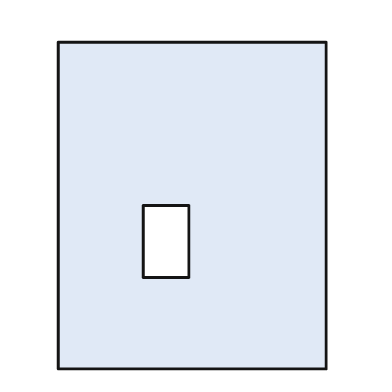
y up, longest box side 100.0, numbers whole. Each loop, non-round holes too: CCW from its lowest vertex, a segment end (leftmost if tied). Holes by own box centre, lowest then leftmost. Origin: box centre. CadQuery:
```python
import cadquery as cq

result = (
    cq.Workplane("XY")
    .moveTo(-41.0, -50.0)
    .lineTo(41.0, -50.0)
    .lineTo(41.0, 50.0)
    .lineTo(-41.0, 50.0)
    .close()
    .moveTo(-15.0, -22.0)
    .lineTo(-1.0, -22.0)
    .lineTo(-1.0, 0.0)
    .lineTo(-15.0, 0.0)
    .close()
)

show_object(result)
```